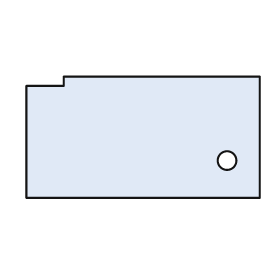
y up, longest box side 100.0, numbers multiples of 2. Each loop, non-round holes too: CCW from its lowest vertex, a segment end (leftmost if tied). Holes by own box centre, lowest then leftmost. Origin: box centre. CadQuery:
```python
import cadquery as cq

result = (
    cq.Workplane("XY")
    .moveTo(-50.0, -26.0)
    .lineTo(50.0, -26.0)
    .lineTo(50.0, 26.0)
    .lineTo(-34.0, 26.0)
    .lineTo(-34.0, 22.0)
    .lineTo(-50.0, 22.0)
    .close()
    .moveTo(36.0, -10.0)
    .circle(4.0)
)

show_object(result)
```